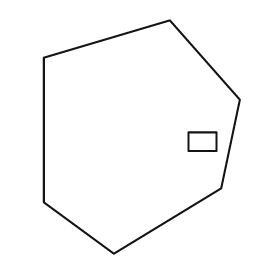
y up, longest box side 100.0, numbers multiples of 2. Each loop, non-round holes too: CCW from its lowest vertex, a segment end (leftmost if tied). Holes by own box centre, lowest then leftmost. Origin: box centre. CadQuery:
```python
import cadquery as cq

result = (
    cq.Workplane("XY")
    .moveTo(-12.0, -50.0)
    .lineTo(34.0, -22.0)
    .lineTo(42.0, 16.0)
    .lineTo(12.0, 50.0)
    .lineTo(-42.0, 34.0)
    .lineTo(-42.0, -28.0)
    .close()
    .moveTo(20.0, -6.0)
    .lineTo(32.0, -6.0)
    .lineTo(32.0, 2.0)
    .lineTo(20.0, 2.0)
    .close()
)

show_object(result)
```